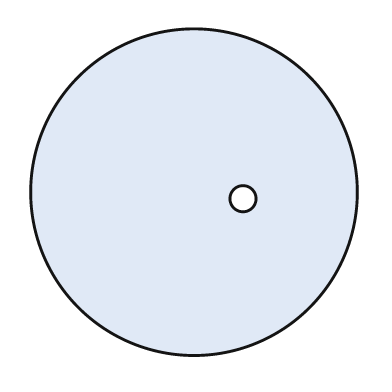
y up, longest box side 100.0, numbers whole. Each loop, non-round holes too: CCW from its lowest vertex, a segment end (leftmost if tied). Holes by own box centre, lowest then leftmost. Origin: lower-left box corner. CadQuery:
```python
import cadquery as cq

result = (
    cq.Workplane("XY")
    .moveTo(50.0, 50.0)
    .circle(50.0)
    .moveTo(65.0, 48.0)
    .circle(4.0)
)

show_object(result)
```